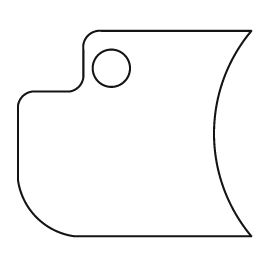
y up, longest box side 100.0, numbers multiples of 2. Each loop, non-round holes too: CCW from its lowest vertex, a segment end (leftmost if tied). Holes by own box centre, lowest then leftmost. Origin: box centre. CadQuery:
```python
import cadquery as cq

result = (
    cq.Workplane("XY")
    .moveTo(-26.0, -44.0)
    .lineTo(50.0, -44.0)
    .threePointArc((34.0, 0.0), (50.0, 44.0))
    .lineTo(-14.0, 44.0)
    .threePointArc((-20.0, 42.0), (-22.0, 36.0))
    .lineTo(-22.0, 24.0)
    .threePointArc((-24.0, 20.0), (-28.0, 18.0))
    .lineTo(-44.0, 18.0)
    .threePointArc((-48.0, 16.0), (-50.0, 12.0))
    .lineTo(-50.0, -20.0)
    .threePointArc((-42.0, -36.0), (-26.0, -44.0))
    .close()
    .moveTo(-10.0, 28.0)
    .circle(8.0)
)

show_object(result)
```